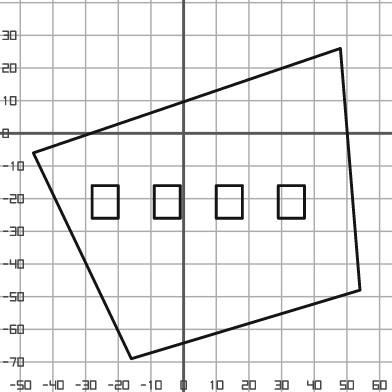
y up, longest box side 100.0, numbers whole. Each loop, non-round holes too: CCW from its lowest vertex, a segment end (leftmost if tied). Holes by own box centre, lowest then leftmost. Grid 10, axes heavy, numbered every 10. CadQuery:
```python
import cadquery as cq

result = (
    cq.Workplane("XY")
    .moveTo(-16.0, -69.0)
    .lineTo(54.0, -48.0)
    .lineTo(48.0, 26.0)
    .lineTo(-46.0, -6.0)
    .close()
    .moveTo(-28.0, -26.0)
    .lineTo(-20.0, -26.0)
    .lineTo(-20.0, -16.0)
    .lineTo(-28.0, -16.0)
    .close()
    .moveTo(-9.0, -26.0)
    .lineTo(-1.0, -26.0)
    .lineTo(-1.0, -16.0)
    .lineTo(-9.0, -16.0)
    .close()
    .moveTo(10.0, -26.0)
    .lineTo(18.0, -26.0)
    .lineTo(18.0, -16.0)
    .lineTo(10.0, -16.0)
    .close()
    .moveTo(29.0, -26.0)
    .lineTo(37.0, -26.0)
    .lineTo(37.0, -16.0)
    .lineTo(29.0, -16.0)
    .close()
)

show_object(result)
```